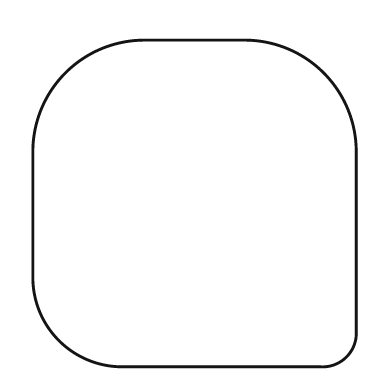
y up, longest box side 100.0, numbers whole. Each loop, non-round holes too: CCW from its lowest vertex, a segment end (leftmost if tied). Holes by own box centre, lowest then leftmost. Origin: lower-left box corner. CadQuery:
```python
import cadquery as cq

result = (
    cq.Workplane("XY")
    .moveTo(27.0, 0.0)
    .lineTo(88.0, 0.0)
    .threePointArc((96.0, 3.0), (99.0, 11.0))
    .lineTo(99.0, 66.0)
    .threePointArc((89.0, 90.0), (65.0, 100.0))
    .lineTo(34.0, 100.0)
    .threePointArc((10.0, 90.0), (0.0, 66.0))
    .lineTo(0.0, 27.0)
    .threePointArc((8.0, 8.0), (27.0, 0.0))
    .close()
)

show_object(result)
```